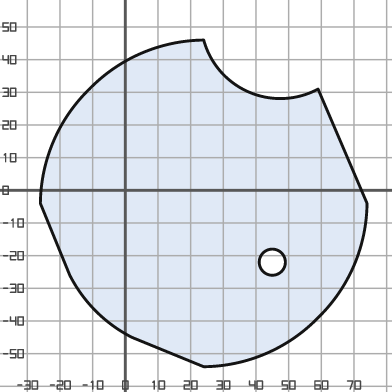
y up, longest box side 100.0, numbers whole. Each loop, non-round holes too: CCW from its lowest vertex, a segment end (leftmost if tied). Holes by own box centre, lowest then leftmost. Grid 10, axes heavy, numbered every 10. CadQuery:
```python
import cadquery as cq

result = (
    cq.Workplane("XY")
    .moveTo(24.0, -54.0)
    .threePointArc((43.0, -50.0), (59.0, -39.0))
    .threePointArc((70.0, -23.0), (74.0, -4.0))
    .lineTo(59.0, 31.0)
    .threePointArc((38.0, 30.0), (24.0, 46.0))
    .threePointArc((5.0, 42.0), (-11.0, 31.0))
    .threePointArc((-22.0, 15.0), (-26.0, -4.0))
    .lineTo(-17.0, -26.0)
    .threePointArc((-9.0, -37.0), (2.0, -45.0))
    .close()
    .moveTo(45.0, -22.0)
    .circle(4.0)
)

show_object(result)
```